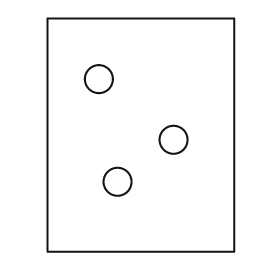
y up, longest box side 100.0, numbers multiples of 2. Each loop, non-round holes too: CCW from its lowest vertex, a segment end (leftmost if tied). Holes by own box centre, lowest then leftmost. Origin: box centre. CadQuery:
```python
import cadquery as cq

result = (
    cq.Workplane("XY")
    .moveTo(-40.0, -50.0)
    .lineTo(40.0, -50.0)
    .lineTo(40.0, 50.0)
    .lineTo(-40.0, 50.0)
    .close()
    .moveTo(-10.0, -20.0)
    .circle(6.0)
    .moveTo(14.0, -2.0)
    .circle(6.0)
    .moveTo(-18.0, 24.0)
    .circle(6.0)
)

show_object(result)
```